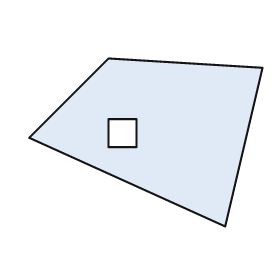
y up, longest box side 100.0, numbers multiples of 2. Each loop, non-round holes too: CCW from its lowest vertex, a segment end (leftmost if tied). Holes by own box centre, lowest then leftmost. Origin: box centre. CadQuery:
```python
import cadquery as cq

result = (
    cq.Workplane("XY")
    .moveTo(34.0, -36.0)
    .lineTo(50.0, 32.0)
    .lineTo(-16.0, 36.0)
    .lineTo(-50.0, 2.0)
    .close()
    .moveTo(-16.0, -2.0)
    .lineTo(-4.0, -2.0)
    .lineTo(-4.0, 10.0)
    .lineTo(-16.0, 10.0)
    .close()
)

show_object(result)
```